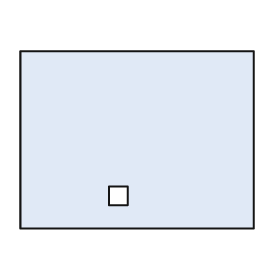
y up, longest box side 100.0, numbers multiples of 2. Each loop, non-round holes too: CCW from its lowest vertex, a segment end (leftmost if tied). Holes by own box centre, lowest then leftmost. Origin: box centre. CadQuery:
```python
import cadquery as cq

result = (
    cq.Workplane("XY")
    .moveTo(-50.0, -38.0)
    .lineTo(50.0, -38.0)
    .lineTo(50.0, 38.0)
    .lineTo(-50.0, 38.0)
    .close()
    .moveTo(-12.0, -28.0)
    .lineTo(-4.0, -28.0)
    .lineTo(-4.0, -20.0)
    .lineTo(-12.0, -20.0)
    .close()
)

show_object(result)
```